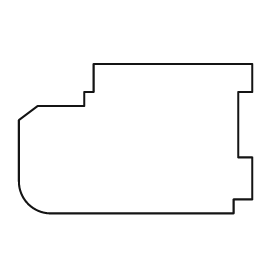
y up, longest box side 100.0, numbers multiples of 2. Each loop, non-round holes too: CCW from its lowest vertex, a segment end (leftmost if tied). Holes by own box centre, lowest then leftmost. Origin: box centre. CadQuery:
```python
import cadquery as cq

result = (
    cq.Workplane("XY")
    .moveTo(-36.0, -32.0)
    .lineTo(42.0, -32.0)
    .lineTo(42.0, -26.0)
    .lineTo(50.0, -26.0)
    .lineTo(50.0, -8.0)
    .lineTo(44.0, -8.0)
    .lineTo(44.0, 20.0)
    .lineTo(50.0, 20.0)
    .lineTo(50.0, 32.0)
    .lineTo(-18.0, 32.0)
    .lineTo(-18.0, 20.0)
    .lineTo(-22.0, 20.0)
    .lineTo(-22.0, 14.0)
    .lineTo(-42.0, 14.0)
    .lineTo(-50.0, 8.0)
    .lineTo(-50.0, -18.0)
    .threePointArc((-46.0, -28.0), (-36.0, -32.0))
    .close()
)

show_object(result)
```